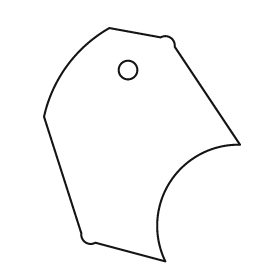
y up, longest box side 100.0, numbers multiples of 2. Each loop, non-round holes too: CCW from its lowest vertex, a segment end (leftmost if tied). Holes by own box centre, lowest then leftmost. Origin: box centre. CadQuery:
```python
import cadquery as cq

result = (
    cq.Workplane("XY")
    .moveTo(10.0, -50.0)
    .threePointArc((12.0, -16.0), (42.0, 0.0))
    .lineTo(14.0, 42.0)
    .threePointArc((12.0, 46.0), (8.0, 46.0))
    .lineTo(-14.0, 50.0)
    .threePointArc((-32.0, 34.0), (-42.0, 12.0))
    .lineTo(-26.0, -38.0)
    .threePointArc((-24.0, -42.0), (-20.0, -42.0))
    .close()
    .moveTo(-6.0, 32.0)
    .circle(4.0)
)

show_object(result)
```